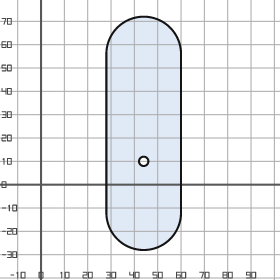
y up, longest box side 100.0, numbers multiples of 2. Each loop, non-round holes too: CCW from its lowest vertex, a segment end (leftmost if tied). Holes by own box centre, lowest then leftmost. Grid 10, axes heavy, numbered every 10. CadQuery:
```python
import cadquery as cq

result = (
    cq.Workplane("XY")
    .moveTo(28.0, -12.0)
    .threePointArc((44.0, -28.0), (60.0, -12.0))
    .lineTo(60.0, 56.0)
    .threePointArc((44.0, 72.0), (28.0, 56.0))
    .close()
    .moveTo(44.0, 10.0)
    .circle(2.0)
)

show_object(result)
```